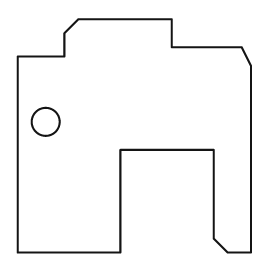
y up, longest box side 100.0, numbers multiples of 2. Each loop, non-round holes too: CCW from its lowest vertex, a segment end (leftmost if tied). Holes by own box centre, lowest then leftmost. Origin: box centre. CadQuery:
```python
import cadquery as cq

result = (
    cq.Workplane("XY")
    .moveTo(-50.0, -50.0)
    .lineTo(-6.0, -50.0)
    .lineTo(-6.0, -6.0)
    .lineTo(34.0, -6.0)
    .lineTo(34.0, -44.0)
    .lineTo(40.0, -50.0)
    .lineTo(50.0, -50.0)
    .lineTo(50.0, 30.0)
    .lineTo(46.0, 38.0)
    .lineTo(16.0, 38.0)
    .lineTo(16.0, 50.0)
    .lineTo(-24.0, 50.0)
    .lineTo(-30.0, 44.0)
    .lineTo(-30.0, 34.0)
    .lineTo(-50.0, 34.0)
    .close()
    .moveTo(-38.0, 6.0)
    .circle(6.0)
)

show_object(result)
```